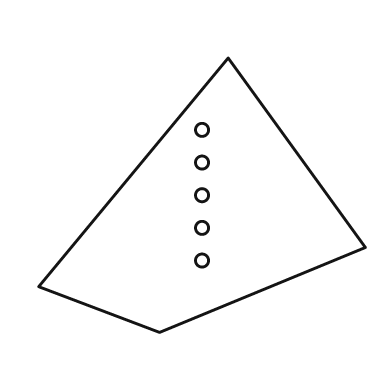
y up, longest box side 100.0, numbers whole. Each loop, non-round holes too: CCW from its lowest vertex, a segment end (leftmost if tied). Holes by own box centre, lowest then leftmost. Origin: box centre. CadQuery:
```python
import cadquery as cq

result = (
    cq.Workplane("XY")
    .moveTo(-13.0, -42.0)
    .lineTo(50.0, -16.0)
    .lineTo(8.0, 42.0)
    .lineTo(-50.0, -28.0)
    .close()
    .moveTo(0.0, -20.0)
    .circle(2.0)
    .moveTo(0.0, -10.0)
    .circle(2.0)
    .moveTo(0.0, 0.0)
    .circle(2.0)
    .moveTo(0.0, 10.0)
    .circle(2.0)
    .moveTo(0.0, 20.0)
    .circle(2.0)
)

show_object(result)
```